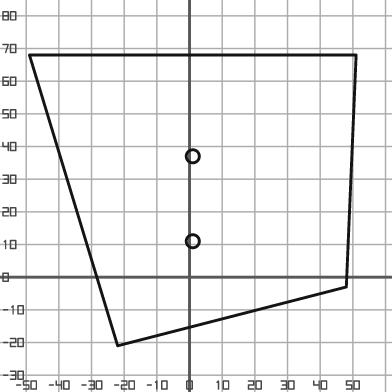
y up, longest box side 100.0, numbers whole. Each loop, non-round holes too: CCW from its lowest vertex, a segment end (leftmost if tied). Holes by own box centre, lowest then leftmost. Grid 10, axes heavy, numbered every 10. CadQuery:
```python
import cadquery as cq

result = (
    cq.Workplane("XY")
    .moveTo(-22.0, -21.0)
    .lineTo(48.0, -3.0)
    .lineTo(51.0, 68.0)
    .lineTo(-49.0, 68.0)
    .close()
    .moveTo(1.0, 11.0)
    .circle(2.0)
    .moveTo(1.0, 37.0)
    .circle(2.0)
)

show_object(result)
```